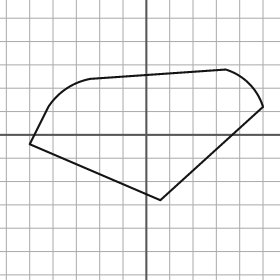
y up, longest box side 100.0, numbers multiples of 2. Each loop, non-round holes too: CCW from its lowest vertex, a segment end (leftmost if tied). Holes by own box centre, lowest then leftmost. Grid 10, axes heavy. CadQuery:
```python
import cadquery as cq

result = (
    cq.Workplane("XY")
    .moveTo(6.0, -28.0)
    .lineTo(50.0, 12.0)
    .threePointArc((44.0, 22.0), (34.0, 28.0))
    .lineTo(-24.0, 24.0)
    .threePointArc((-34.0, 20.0), (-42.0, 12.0))
    .lineTo(-50.0, -4.0)
    .close()
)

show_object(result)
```